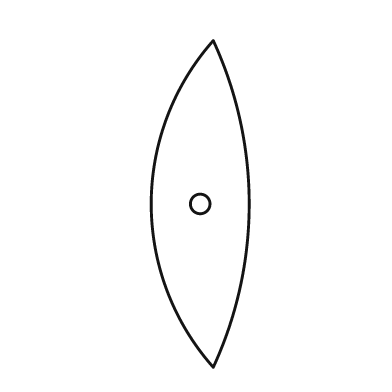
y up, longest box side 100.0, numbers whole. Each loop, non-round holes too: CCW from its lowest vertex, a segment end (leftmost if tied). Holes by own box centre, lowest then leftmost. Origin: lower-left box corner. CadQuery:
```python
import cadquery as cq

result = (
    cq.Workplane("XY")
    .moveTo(19.0, 0.0)
    .threePointArc((30.0, 50.0), (19.0, 100.0))
    .threePointArc((0.0, 50.0), (19.0, 0.0))
    .close()
    .moveTo(15.0, 50.0)
    .circle(3.0)
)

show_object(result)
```